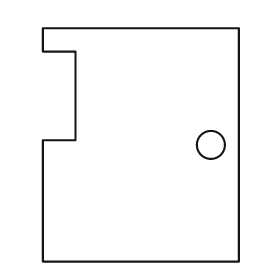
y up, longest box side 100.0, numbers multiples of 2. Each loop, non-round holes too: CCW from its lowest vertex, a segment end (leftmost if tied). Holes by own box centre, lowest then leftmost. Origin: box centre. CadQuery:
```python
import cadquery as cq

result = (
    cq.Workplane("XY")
    .moveTo(-42.0, -50.0)
    .lineTo(42.0, -50.0)
    .lineTo(42.0, 50.0)
    .lineTo(-42.0, 50.0)
    .lineTo(-42.0, 40.0)
    .lineTo(-28.0, 40.0)
    .lineTo(-28.0, 2.0)
    .lineTo(-42.0, 2.0)
    .close()
    .moveTo(30.0, 0.0)
    .circle(6.0)
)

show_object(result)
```